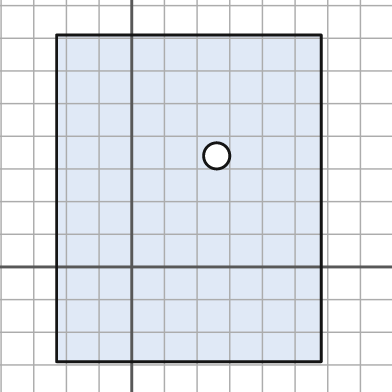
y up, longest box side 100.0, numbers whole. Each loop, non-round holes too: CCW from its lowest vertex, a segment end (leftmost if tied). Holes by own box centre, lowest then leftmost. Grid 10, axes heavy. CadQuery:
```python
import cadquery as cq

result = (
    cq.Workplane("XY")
    .moveTo(-23.0, -29.0)
    .lineTo(58.0, -29.0)
    .lineTo(58.0, 71.0)
    .lineTo(-23.0, 71.0)
    .close()
    .moveTo(26.0, 34.0)
    .circle(4.0)
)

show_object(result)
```